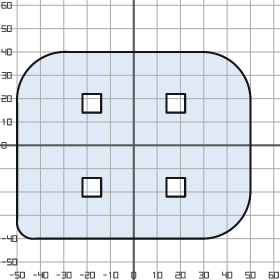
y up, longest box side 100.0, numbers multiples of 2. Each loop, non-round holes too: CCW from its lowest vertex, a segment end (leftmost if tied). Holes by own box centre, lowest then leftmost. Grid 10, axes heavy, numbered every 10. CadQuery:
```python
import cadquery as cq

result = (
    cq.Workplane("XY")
    .moveTo(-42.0, -40.0)
    .lineTo(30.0, -40.0)
    .threePointArc((44.0, -34.0), (50.0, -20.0))
    .lineTo(50.0, 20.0)
    .threePointArc((44.0, 34.0), (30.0, 40.0))
    .lineTo(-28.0, 40.0)
    .threePointArc((-44.0, 34.0), (-50.0, 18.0))
    .lineTo(-50.0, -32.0)
    .threePointArc((-48.0, -38.0), (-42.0, -40.0))
    .close()
    .moveTo(-22.0, -22.0)
    .lineTo(-14.0, -22.0)
    .lineTo(-14.0, -14.0)
    .lineTo(-22.0, -14.0)
    .close()
    .moveTo(14.0, -22.0)
    .lineTo(22.0, -22.0)
    .lineTo(22.0, -14.0)
    .lineTo(14.0, -14.0)
    .close()
    .moveTo(-22.0, 14.0)
    .lineTo(-14.0, 14.0)
    .lineTo(-14.0, 22.0)
    .lineTo(-22.0, 22.0)
    .close()
    .moveTo(14.0, 14.0)
    .lineTo(22.0, 14.0)
    .lineTo(22.0, 22.0)
    .lineTo(14.0, 22.0)
    .close()
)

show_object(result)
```